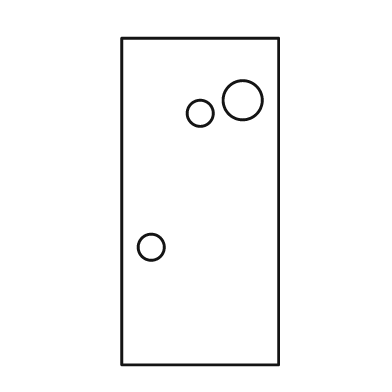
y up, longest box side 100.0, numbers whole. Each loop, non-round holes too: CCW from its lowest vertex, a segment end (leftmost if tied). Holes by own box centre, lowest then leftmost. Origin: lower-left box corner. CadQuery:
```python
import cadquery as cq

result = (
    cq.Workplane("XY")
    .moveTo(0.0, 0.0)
    .lineTo(48.0, 0.0)
    .lineTo(48.0, 100.0)
    .lineTo(0.0, 100.0)
    .close()
    .moveTo(9.0, 36.0)
    .circle(4.0)
    .moveTo(24.0, 77.0)
    .circle(4.0)
    .moveTo(37.0, 81.0)
    .circle(6.0)
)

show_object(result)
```